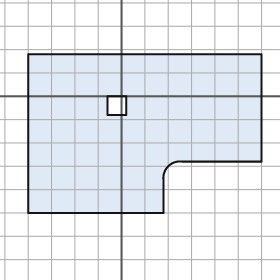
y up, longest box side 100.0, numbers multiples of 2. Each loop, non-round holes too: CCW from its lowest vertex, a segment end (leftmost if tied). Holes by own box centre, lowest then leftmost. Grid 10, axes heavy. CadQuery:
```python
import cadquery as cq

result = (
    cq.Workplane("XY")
    .moveTo(-40.0, -50.0)
    .lineTo(18.0, -50.0)
    .lineTo(18.0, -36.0)
    .threePointArc((20.0, -30.0), (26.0, -28.0))
    .lineTo(60.0, -28.0)
    .lineTo(60.0, 18.0)
    .lineTo(-40.0, 18.0)
    .close()
    .moveTo(-6.0, -8.0)
    .lineTo(2.0, -8.0)
    .lineTo(2.0, 0.0)
    .lineTo(-6.0, 0.0)
    .close()
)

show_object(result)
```